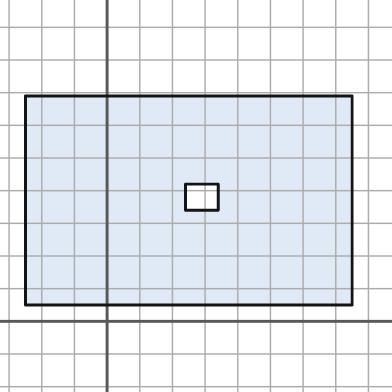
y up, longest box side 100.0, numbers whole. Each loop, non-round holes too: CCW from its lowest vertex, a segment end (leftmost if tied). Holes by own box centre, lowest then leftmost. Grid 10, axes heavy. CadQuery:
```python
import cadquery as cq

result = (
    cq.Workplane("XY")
    .moveTo(-25.0, 5.0)
    .lineTo(75.0, 5.0)
    .lineTo(75.0, 69.0)
    .lineTo(-25.0, 69.0)
    .close()
    .moveTo(24.0, 34.0)
    .lineTo(34.0, 34.0)
    .lineTo(34.0, 42.0)
    .lineTo(24.0, 42.0)
    .close()
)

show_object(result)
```